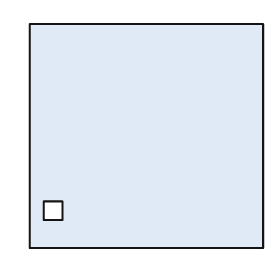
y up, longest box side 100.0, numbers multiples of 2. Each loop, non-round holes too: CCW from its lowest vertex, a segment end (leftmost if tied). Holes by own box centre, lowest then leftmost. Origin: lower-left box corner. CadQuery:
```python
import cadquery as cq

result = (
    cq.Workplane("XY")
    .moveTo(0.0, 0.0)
    .lineTo(100.0, 0.0)
    .lineTo(100.0, 96.0)
    .lineTo(0.0, 96.0)
    .close()
    .moveTo(6.0, 12.0)
    .lineTo(14.0, 12.0)
    .lineTo(14.0, 20.0)
    .lineTo(6.0, 20.0)
    .close()
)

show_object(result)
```